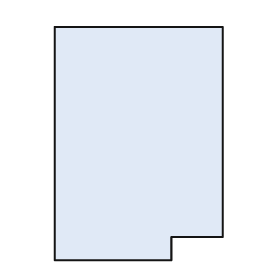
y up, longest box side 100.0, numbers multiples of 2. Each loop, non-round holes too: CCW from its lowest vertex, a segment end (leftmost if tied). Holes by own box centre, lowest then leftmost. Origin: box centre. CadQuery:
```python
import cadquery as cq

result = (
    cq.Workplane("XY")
    .moveTo(-36.0, -50.0)
    .lineTo(14.0, -50.0)
    .lineTo(14.0, -40.0)
    .lineTo(36.0, -40.0)
    .lineTo(36.0, 50.0)
    .lineTo(-36.0, 50.0)
    .close()
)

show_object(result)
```